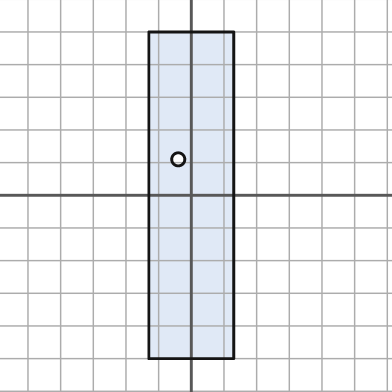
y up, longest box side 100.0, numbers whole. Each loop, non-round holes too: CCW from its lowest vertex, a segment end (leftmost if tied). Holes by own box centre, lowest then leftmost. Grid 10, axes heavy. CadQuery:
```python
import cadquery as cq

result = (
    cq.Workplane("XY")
    .moveTo(-13.0, -50.0)
    .lineTo(13.0, -50.0)
    .lineTo(13.0, 50.0)
    .lineTo(-13.0, 50.0)
    .close()
    .moveTo(-4.0, 11.0)
    .circle(2.0)
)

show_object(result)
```